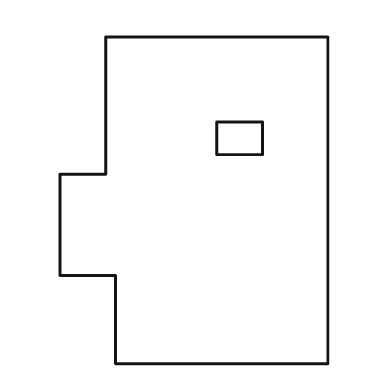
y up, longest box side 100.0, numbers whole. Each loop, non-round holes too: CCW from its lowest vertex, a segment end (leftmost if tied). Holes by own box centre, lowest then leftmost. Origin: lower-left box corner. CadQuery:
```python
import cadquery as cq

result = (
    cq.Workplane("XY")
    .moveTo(17.0, 0.0)
    .lineTo(82.0, 0.0)
    .lineTo(82.0, 100.0)
    .lineTo(14.0, 100.0)
    .lineTo(14.0, 58.0)
    .lineTo(0.0, 58.0)
    .lineTo(0.0, 27.0)
    .lineTo(17.0, 27.0)
    .close()
    .moveTo(48.0, 64.0)
    .lineTo(62.0, 64.0)
    .lineTo(62.0, 74.0)
    .lineTo(48.0, 74.0)
    .close()
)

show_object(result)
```